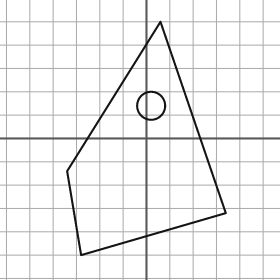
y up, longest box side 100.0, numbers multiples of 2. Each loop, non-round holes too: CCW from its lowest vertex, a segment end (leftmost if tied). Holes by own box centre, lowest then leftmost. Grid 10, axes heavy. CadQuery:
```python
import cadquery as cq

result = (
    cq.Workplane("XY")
    .moveTo(-28.0, -50.0)
    .lineTo(34.0, -32.0)
    .lineTo(6.0, 50.0)
    .lineTo(-34.0, -14.0)
    .close()
    .moveTo(2.0, 14.0)
    .circle(6.0)
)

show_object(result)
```